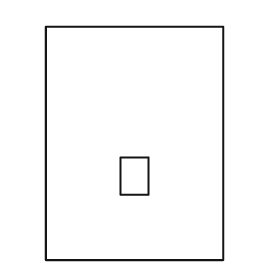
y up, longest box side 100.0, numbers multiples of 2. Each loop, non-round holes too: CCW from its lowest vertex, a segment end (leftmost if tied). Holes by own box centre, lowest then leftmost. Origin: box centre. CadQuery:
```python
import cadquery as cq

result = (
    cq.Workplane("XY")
    .moveTo(-38.0, -50.0)
    .lineTo(38.0, -50.0)
    .lineTo(38.0, 50.0)
    .lineTo(-38.0, 50.0)
    .close()
    .moveTo(-6.0, -22.0)
    .lineTo(6.0, -22.0)
    .lineTo(6.0, -6.0)
    .lineTo(-6.0, -6.0)
    .close()
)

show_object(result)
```